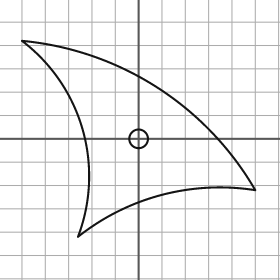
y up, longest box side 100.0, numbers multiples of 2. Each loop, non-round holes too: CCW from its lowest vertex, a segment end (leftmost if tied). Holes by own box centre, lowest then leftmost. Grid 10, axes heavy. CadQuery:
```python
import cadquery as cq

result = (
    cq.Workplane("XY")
    .moveTo(-26.0, -42.0)
    .threePointArc((10.0, -24.0), (50.0, -22.0))
    .threePointArc((8.0, 22.0), (-50.0, 42.0))
    .threePointArc((-24.0, 4.0), (-26.0, -42.0))
    .close()
    .moveTo(0.0, 0.0)
    .circle(4.0)
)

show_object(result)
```